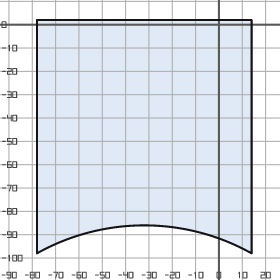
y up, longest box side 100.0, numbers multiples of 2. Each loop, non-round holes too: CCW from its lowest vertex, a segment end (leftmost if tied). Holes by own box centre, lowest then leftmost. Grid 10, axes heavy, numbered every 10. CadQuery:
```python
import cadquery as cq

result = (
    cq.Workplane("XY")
    .moveTo(-78.0, -98.0)
    .threePointArc((-32.0, -86.0), (14.0, -98.0))
    .lineTo(14.0, 2.0)
    .lineTo(-78.0, 2.0)
    .close()
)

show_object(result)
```